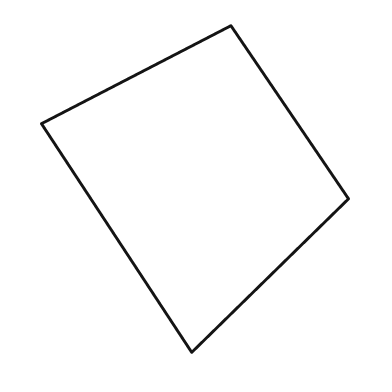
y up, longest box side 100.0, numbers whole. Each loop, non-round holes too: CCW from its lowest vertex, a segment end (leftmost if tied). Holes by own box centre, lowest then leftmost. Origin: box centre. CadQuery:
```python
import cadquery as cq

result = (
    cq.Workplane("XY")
    .moveTo(-1.0, -50.0)
    .lineTo(47.0, -3.0)
    .lineTo(11.0, 50.0)
    .lineTo(-47.0, 20.0)
    .close()
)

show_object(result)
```